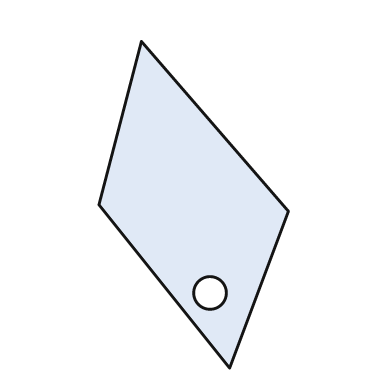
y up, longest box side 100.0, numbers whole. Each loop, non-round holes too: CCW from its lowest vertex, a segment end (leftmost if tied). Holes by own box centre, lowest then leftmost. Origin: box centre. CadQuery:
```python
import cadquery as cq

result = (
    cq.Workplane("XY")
    .moveTo(11.0, -50.0)
    .lineTo(29.0, -2.0)
    .lineTo(-16.0, 50.0)
    .lineTo(-29.0, 0.0)
    .close()
    .moveTo(5.0, -27.0)
    .circle(5.0)
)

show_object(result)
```